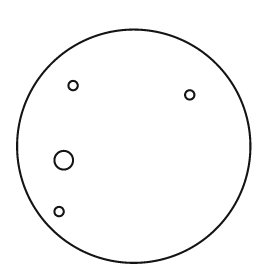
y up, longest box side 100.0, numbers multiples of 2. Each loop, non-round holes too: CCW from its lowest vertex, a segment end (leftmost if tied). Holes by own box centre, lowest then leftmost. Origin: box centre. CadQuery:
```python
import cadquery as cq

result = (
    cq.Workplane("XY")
    .moveTo(0.0, 0.0)
    .circle(50.0)
    .moveTo(-32.0, -28.0)
    .circle(2.0)
    .moveTo(-30.0, -6.0)
    .circle(4.0)
    .moveTo(24.0, 22.0)
    .circle(2.0)
    .moveTo(-26.0, 26.0)
    .circle(2.0)
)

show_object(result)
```